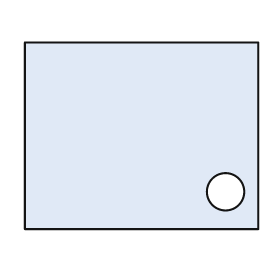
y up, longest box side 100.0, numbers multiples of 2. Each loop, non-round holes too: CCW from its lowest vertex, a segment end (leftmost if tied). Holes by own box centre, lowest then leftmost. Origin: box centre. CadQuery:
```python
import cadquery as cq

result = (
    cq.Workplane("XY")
    .moveTo(-50.0, -40.0)
    .lineTo(50.0, -40.0)
    .lineTo(50.0, 40.0)
    .lineTo(-50.0, 40.0)
    .close()
    .moveTo(36.0, -24.0)
    .circle(8.0)
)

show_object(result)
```